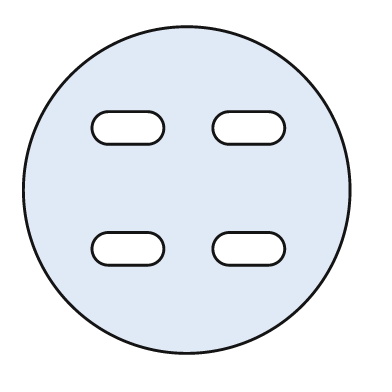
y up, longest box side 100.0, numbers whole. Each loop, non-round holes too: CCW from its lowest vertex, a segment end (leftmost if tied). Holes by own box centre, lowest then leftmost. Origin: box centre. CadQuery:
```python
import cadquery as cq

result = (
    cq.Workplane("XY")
    .moveTo(0.0, 0.0)
    .circle(50.0)
    .moveTo(-24.0, -23.0)
    .lineTo(-12.0, -23.0)
    .threePointArc((-7.0, -18.0), (-12.0, -13.0))
    .lineTo(-24.0, -13.0)
    .threePointArc((-29.0, -18.0), (-24.0, -23.0))
    .close()
    .moveTo(13.0, -23.0)
    .lineTo(25.0, -23.0)
    .threePointArc((30.0, -18.0), (25.0, -13.0))
    .lineTo(13.0, -13.0)
    .threePointArc((8.0, -18.0), (13.0, -23.0))
    .close()
    .moveTo(-24.0, 14.0)
    .lineTo(-12.0, 14.0)
    .threePointArc((-7.0, 19.0), (-12.0, 24.0))
    .lineTo(-24.0, 24.0)
    .threePointArc((-29.0, 19.0), (-24.0, 14.0))
    .close()
    .moveTo(13.0, 14.0)
    .lineTo(25.0, 14.0)
    .threePointArc((30.0, 19.0), (25.0, 24.0))
    .lineTo(13.0, 24.0)
    .threePointArc((8.0, 19.0), (13.0, 14.0))
    .close()
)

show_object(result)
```